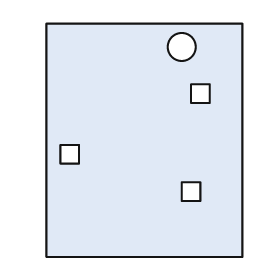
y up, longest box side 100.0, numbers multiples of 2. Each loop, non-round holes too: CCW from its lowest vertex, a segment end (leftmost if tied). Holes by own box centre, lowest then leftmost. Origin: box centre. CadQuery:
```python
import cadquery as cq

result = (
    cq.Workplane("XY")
    .moveTo(-42.0, -50.0)
    .lineTo(42.0, -50.0)
    .lineTo(42.0, 50.0)
    .lineTo(-42.0, 50.0)
    .close()
    .moveTo(16.0, -26.0)
    .lineTo(24.0, -26.0)
    .lineTo(24.0, -18.0)
    .lineTo(16.0, -18.0)
    .close()
    .moveTo(-36.0, -10.0)
    .lineTo(-28.0, -10.0)
    .lineTo(-28.0, -2.0)
    .lineTo(-36.0, -2.0)
    .close()
    .moveTo(20.0, 16.0)
    .lineTo(28.0, 16.0)
    .lineTo(28.0, 24.0)
    .lineTo(20.0, 24.0)
    .close()
    .moveTo(16.0, 40.0)
    .circle(6.0)
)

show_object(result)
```